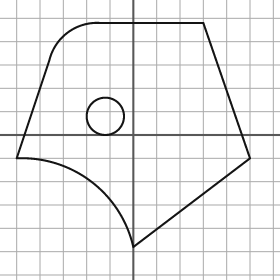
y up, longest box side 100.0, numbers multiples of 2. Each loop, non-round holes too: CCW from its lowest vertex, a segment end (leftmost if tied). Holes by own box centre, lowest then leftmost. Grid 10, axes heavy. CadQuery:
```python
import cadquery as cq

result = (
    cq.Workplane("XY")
    .moveTo(0.0, -48.0)
    .lineTo(50.0, -10.0)
    .lineTo(30.0, 48.0)
    .lineTo(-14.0, 48.0)
    .threePointArc((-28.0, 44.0), (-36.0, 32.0))
    .lineTo(-50.0, -10.0)
    .threePointArc((-18.0, -20.0), (0.0, -48.0))
    .close()
    .moveTo(-12.0, 8.0)
    .circle(8.0)
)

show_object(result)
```